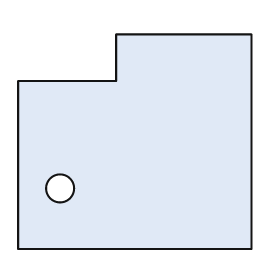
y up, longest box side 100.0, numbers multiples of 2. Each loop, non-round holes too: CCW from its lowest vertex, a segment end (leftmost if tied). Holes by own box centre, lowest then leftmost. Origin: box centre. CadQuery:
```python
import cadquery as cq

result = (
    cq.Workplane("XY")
    .moveTo(-50.0, -46.0)
    .lineTo(50.0, -46.0)
    .lineTo(50.0, 46.0)
    .lineTo(-8.0, 46.0)
    .lineTo(-8.0, 26.0)
    .lineTo(-50.0, 26.0)
    .close()
    .moveTo(-32.0, -20.0)
    .circle(6.0)
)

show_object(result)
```